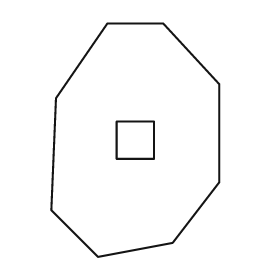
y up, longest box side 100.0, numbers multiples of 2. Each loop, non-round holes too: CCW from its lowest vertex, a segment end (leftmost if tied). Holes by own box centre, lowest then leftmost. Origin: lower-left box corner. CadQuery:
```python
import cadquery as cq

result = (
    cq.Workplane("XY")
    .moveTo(20.0, 0.0)
    .lineTo(52.0, 6.0)
    .lineTo(72.0, 32.0)
    .lineTo(72.0, 74.0)
    .lineTo(48.0, 100.0)
    .lineTo(24.0, 100.0)
    .lineTo(2.0, 68.0)
    .lineTo(0.0, 20.0)
    .close()
    .moveTo(28.0, 42.0)
    .lineTo(44.0, 42.0)
    .lineTo(44.0, 58.0)
    .lineTo(28.0, 58.0)
    .close()
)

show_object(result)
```